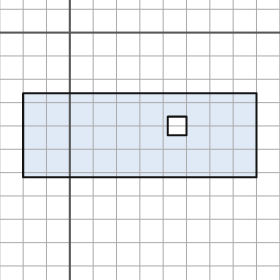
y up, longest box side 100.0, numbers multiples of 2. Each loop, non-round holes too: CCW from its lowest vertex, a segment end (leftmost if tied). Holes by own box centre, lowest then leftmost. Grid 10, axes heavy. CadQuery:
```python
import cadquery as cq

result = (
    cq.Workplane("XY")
    .moveTo(-20.0, -62.0)
    .lineTo(80.0, -62.0)
    .lineTo(80.0, -26.0)
    .lineTo(-20.0, -26.0)
    .close()
    .moveTo(42.0, -44.0)
    .lineTo(50.0, -44.0)
    .lineTo(50.0, -36.0)
    .lineTo(42.0, -36.0)
    .close()
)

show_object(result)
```